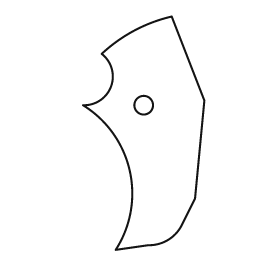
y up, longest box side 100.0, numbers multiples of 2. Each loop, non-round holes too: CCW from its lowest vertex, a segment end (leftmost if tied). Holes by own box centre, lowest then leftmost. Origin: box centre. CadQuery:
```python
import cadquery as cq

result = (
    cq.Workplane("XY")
    .moveTo(-12.0, -50.0)
    .lineTo(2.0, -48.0)
    .threePointArc((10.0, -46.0), (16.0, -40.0))
    .lineTo(22.0, -28.0)
    .lineTo(26.0, 14.0)
    .lineTo(12.0, 50.0)
    .threePointArc((-4.0, 44.0), (-18.0, 34.0))
    .threePointArc((-14.0, 20.0), (-26.0, 12.0))
    .threePointArc((-6.0, -16.0), (-12.0, -50.0))
    .close()
    .moveTo(0.0, 12.0)
    .circle(4.0)
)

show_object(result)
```